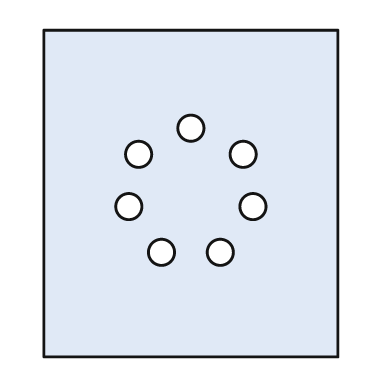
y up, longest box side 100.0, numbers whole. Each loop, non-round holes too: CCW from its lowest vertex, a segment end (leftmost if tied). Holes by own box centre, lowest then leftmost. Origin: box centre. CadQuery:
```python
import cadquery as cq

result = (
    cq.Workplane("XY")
    .moveTo(-45.0, -50.0)
    .lineTo(45.0, -50.0)
    .lineTo(45.0, 50.0)
    .lineTo(-45.0, 50.0)
    .close()
    .moveTo(-9.0, -18.0)
    .circle(4.0)
    .moveTo(9.0, -18.0)
    .circle(4.0)
    .moveTo(-19.0, -4.0)
    .circle(4.0)
    .moveTo(19.0, -4.0)
    .circle(4.0)
    .moveTo(-16.0, 12.0)
    .circle(4.0)
    .moveTo(16.0, 12.0)
    .circle(4.0)
    .moveTo(0.0, 20.0)
    .circle(4.0)
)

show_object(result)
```